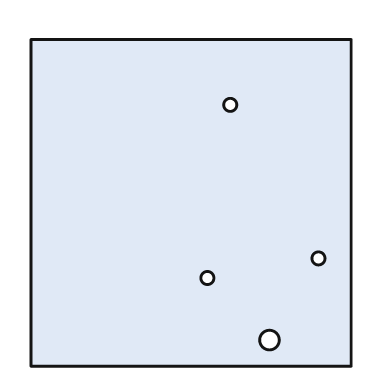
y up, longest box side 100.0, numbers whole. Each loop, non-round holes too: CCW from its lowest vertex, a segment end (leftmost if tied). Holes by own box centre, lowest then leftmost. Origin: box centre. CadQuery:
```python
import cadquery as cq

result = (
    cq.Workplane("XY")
    .moveTo(-49.0, -50.0)
    .lineTo(49.0, -50.0)
    .lineTo(49.0, 50.0)
    .lineTo(-49.0, 50.0)
    .close()
    .moveTo(24.0, -42.0)
    .circle(3.0)
    .moveTo(5.0, -23.0)
    .circle(2.0)
    .moveTo(39.0, -17.0)
    .circle(2.0)
    .moveTo(12.0, 30.0)
    .circle(2.0)
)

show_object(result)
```